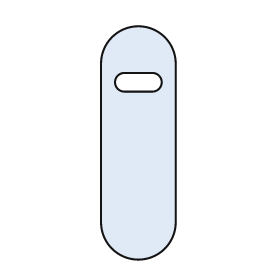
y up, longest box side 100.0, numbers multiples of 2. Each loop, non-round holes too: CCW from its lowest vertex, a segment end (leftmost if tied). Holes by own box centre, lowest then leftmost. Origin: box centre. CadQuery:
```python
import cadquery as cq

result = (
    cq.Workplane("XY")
    .moveTo(-16.0, -34.0)
    .threePointArc((0.0, -50.0), (16.0, -34.0))
    .lineTo(16.0, 34.0)
    .threePointArc((0.0, 50.0), (-16.0, 34.0))
    .close()
    .moveTo(-6.0, 22.0)
    .lineTo(6.0, 22.0)
    .threePointArc((10.0, 26.0), (6.0, 30.0))
    .lineTo(-6.0, 30.0)
    .threePointArc((-10.0, 26.0), (-6.0, 22.0))
    .close()
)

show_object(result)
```